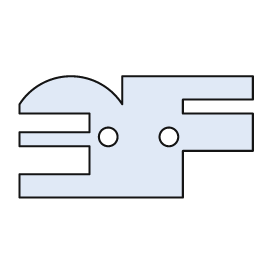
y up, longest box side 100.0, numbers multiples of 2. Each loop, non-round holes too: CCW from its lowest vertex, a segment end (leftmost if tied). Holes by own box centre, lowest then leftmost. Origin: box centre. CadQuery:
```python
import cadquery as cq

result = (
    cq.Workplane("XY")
    .moveTo(-50.0, -26.0)
    .lineTo(20.0, -26.0)
    .lineTo(20.0, -6.0)
    .lineTo(50.0, -6.0)
    .lineTo(50.0, 10.0)
    .lineTo(20.0, 10.0)
    .lineTo(20.0, 16.0)
    .lineTo(50.0, 16.0)
    .lineTo(50.0, 26.0)
    .lineTo(-6.0, 26.0)
    .lineTo(-6.0, 14.0)
    .threePointArc((-28.0, 26.0), (-50.0, 14.0))
    .lineTo(-50.0, 10.0)
    .lineTo(-20.0, 10.0)
    .lineTo(-20.0, 2.0)
    .lineTo(-50.0, 2.0)
    .lineTo(-50.0, -4.0)
    .lineTo(-20.0, -4.0)
    .lineTo(-20.0, -16.0)
    .lineTo(-50.0, -16.0)
    .close()
    .moveTo(-12.0, 0.0)
    .circle(4.0)
    .moveTo(14.0, 0.0)
    .circle(4.0)
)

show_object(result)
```